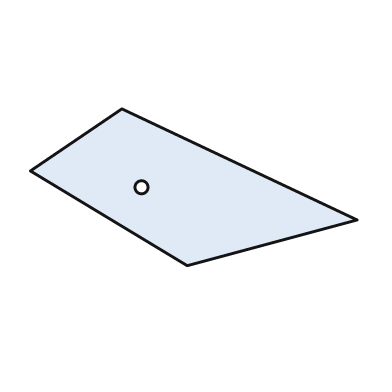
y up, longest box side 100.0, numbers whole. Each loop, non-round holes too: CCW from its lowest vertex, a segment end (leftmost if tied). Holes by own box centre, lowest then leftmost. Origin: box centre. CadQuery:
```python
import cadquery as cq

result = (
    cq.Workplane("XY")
    .moveTo(-2.0, -24.0)
    .lineTo(50.0, -10.0)
    .lineTo(-22.0, 24.0)
    .lineTo(-50.0, 5.0)
    .close()
    .moveTo(-16.0, 0.0)
    .circle(2.0)
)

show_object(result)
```